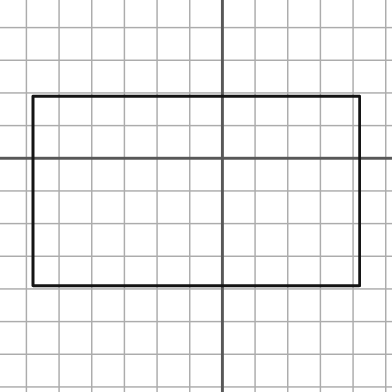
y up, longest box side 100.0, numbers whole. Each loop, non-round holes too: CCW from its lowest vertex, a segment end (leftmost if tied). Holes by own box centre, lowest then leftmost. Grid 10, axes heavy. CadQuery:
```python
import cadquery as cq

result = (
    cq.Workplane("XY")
    .moveTo(-58.0, -39.0)
    .lineTo(42.0, -39.0)
    .lineTo(42.0, 19.0)
    .lineTo(-58.0, 19.0)
    .close()
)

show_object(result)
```